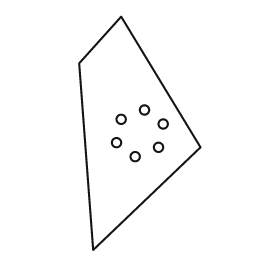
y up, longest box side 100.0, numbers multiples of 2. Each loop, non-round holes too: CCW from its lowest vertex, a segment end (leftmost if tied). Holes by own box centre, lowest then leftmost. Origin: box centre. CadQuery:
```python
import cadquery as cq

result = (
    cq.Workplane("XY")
    .moveTo(-20.0, -50.0)
    .lineTo(26.0, -6.0)
    .lineTo(-8.0, 50.0)
    .lineTo(-26.0, 30.0)
    .close()
    .moveTo(-2.0, -10.0)
    .circle(2.0)
    .moveTo(8.0, -6.0)
    .circle(2.0)
    .moveTo(-10.0, -4.0)
    .circle(2.0)
    .moveTo(10.0, 4.0)
    .circle(2.0)
    .moveTo(-8.0, 6.0)
    .circle(2.0)
    .moveTo(2.0, 10.0)
    .circle(2.0)
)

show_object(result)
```